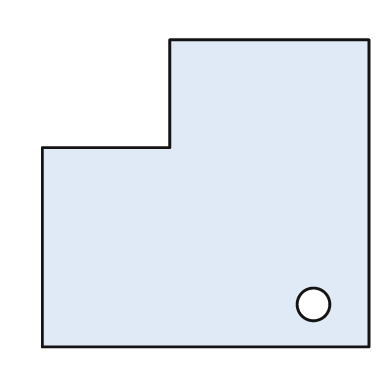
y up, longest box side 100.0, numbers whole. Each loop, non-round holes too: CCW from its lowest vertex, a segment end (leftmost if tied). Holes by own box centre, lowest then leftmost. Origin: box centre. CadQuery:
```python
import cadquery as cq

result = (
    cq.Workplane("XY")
    .moveTo(-50.0, -47.0)
    .lineTo(50.0, -47.0)
    .lineTo(50.0, 47.0)
    .lineTo(-11.0, 47.0)
    .lineTo(-11.0, 14.0)
    .lineTo(-50.0, 14.0)
    .close()
    .moveTo(33.0, -34.0)
    .circle(5.0)
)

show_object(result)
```